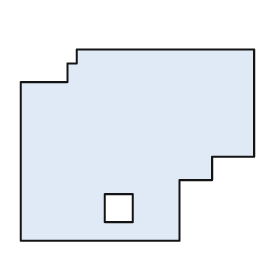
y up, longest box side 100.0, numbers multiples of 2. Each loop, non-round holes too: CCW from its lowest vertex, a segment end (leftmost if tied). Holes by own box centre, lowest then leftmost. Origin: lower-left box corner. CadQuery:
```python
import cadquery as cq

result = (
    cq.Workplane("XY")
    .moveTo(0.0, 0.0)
    .lineTo(68.0, 0.0)
    .lineTo(68.0, 26.0)
    .lineTo(82.0, 26.0)
    .lineTo(82.0, 36.0)
    .lineTo(100.0, 36.0)
    .lineTo(100.0, 82.0)
    .lineTo(24.0, 82.0)
    .lineTo(24.0, 76.0)
    .lineTo(20.0, 76.0)
    .lineTo(20.0, 68.0)
    .lineTo(0.0, 68.0)
    .close()
    .moveTo(36.0, 8.0)
    .lineTo(48.0, 8.0)
    .lineTo(48.0, 20.0)
    .lineTo(36.0, 20.0)
    .close()
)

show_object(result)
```